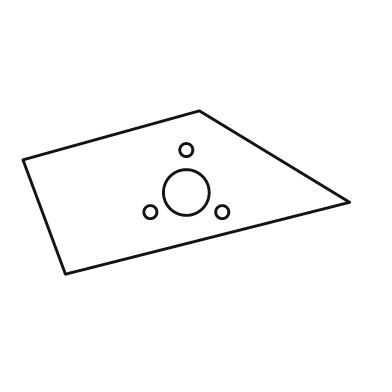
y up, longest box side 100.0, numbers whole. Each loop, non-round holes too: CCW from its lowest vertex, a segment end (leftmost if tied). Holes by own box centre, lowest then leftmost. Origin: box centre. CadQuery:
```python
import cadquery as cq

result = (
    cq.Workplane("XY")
    .moveTo(-37.0, -25.0)
    .lineTo(50.0, -3.0)
    .lineTo(4.0, 25.0)
    .lineTo(-50.0, 10.0)
    .close()
    .moveTo(-11.0, -6.0)
    .circle(2.0)
    .moveTo(11.0, -6.0)
    .circle(2.0)
    .moveTo(0.0, 0.0)
    .circle(7.0)
    .moveTo(0.0, 13.0)
    .circle(2.0)
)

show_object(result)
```